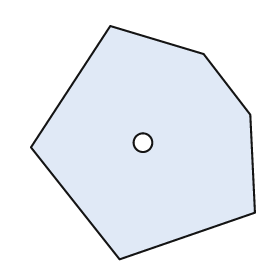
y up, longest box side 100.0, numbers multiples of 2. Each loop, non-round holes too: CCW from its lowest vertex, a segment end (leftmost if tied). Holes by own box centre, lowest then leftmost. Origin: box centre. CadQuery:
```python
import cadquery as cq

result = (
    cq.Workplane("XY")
    .moveTo(-10.0, -50.0)
    .lineTo(48.0, -30.0)
    .lineTo(46.0, 12.0)
    .lineTo(26.0, 38.0)
    .lineTo(-14.0, 50.0)
    .lineTo(-48.0, -2.0)
    .close()
    .moveTo(0.0, 0.0)
    .circle(4.0)
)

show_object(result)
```